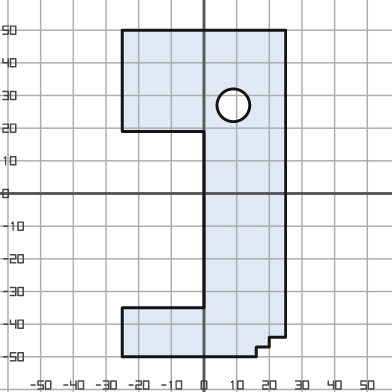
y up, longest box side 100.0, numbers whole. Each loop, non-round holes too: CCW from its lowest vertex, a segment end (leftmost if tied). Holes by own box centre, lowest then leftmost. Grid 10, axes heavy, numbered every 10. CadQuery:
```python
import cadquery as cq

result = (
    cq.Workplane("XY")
    .moveTo(-25.0, -50.0)
    .lineTo(16.0, -50.0)
    .lineTo(16.0, -47.0)
    .lineTo(20.0, -47.0)
    .lineTo(20.0, -44.0)
    .lineTo(25.0, -44.0)
    .lineTo(25.0, 50.0)
    .lineTo(-25.0, 50.0)
    .lineTo(-25.0, 19.0)
    .lineTo(0.0, 19.0)
    .lineTo(0.0, -35.0)
    .lineTo(-25.0, -35.0)
    .close()
    .moveTo(9.0, 27.0)
    .circle(5.0)
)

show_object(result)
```